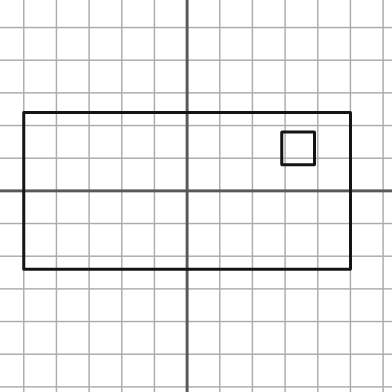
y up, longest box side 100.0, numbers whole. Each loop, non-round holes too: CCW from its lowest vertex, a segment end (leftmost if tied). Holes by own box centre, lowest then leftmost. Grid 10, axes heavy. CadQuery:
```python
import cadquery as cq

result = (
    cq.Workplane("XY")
    .moveTo(-50.0, -24.0)
    .lineTo(50.0, -24.0)
    .lineTo(50.0, 24.0)
    .lineTo(-50.0, 24.0)
    .close()
    .moveTo(29.0, 8.0)
    .lineTo(39.0, 8.0)
    .lineTo(39.0, 18.0)
    .lineTo(29.0, 18.0)
    .close()
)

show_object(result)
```